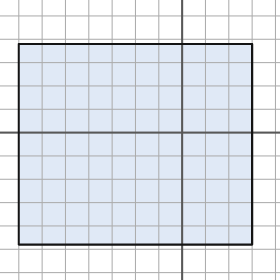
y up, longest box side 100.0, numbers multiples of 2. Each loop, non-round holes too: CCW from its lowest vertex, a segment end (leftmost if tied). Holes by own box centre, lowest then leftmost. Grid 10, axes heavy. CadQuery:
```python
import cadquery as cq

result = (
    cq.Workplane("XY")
    .moveTo(-70.0, -48.0)
    .lineTo(30.0, -48.0)
    .lineTo(30.0, 38.0)
    .lineTo(-70.0, 38.0)
    .close()
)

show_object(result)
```